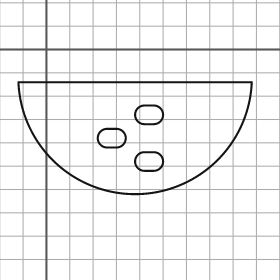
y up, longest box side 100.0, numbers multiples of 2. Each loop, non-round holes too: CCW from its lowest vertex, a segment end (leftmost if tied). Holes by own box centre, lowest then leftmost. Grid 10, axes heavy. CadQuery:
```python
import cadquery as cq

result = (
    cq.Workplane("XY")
    .moveTo(-12.0, -14.0)
    .threePointArc((38.0, -62.0), (88.0, -14.0))
    .close()
    .moveTo(42.0, -52.0)
    .lineTo(46.0, -52.0)
    .threePointArc((50.0, -48.0), (46.0, -44.0))
    .lineTo(42.0, -44.0)
    .threePointArc((38.0, -48.0), (42.0, -52.0))
    .close()
    .moveTo(26.0, -42.0)
    .lineTo(30.0, -42.0)
    .threePointArc((34.0, -38.0), (30.0, -34.0))
    .lineTo(26.0, -34.0)
    .threePointArc((22.0, -38.0), (26.0, -42.0))
    .close()
    .moveTo(42.0, -32.0)
    .lineTo(46.0, -32.0)
    .threePointArc((50.0, -28.0), (46.0, -24.0))
    .lineTo(42.0, -24.0)
    .threePointArc((38.0, -28.0), (42.0, -32.0))
    .close()
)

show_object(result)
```